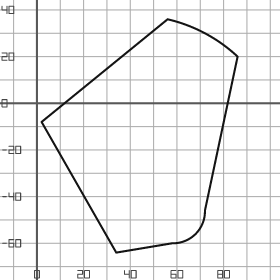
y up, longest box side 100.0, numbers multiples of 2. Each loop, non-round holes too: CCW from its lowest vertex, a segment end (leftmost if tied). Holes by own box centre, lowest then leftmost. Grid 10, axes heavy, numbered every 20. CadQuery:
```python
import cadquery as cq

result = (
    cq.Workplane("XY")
    .moveTo(34.0, -64.0)
    .lineTo(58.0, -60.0)
    .threePointArc((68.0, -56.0), (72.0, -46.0))
    .lineTo(86.0, 20.0)
    .threePointArc((72.0, 30.0), (56.0, 36.0))
    .lineTo(2.0, -8.0)
    .close()
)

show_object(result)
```